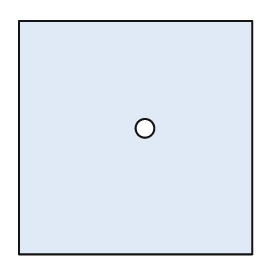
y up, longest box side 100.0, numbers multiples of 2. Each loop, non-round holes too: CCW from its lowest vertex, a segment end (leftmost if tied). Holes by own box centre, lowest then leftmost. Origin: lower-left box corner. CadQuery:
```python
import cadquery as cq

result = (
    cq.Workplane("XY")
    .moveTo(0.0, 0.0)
    .lineTo(100.0, 0.0)
    .lineTo(100.0, 100.0)
    .lineTo(0.0, 100.0)
    .close()
    .moveTo(54.0, 54.0)
    .circle(4.0)
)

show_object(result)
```